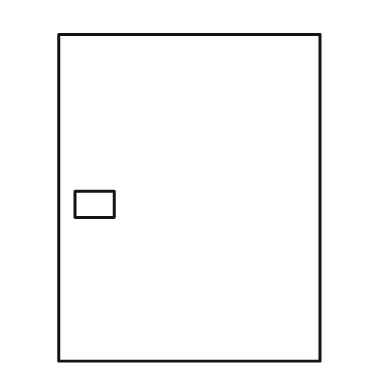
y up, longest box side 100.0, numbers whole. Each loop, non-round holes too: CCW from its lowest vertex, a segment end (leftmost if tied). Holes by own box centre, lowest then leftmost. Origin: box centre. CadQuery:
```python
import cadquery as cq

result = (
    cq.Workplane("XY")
    .moveTo(-40.0, -50.0)
    .lineTo(40.0, -50.0)
    .lineTo(40.0, 50.0)
    .lineTo(-40.0, 50.0)
    .close()
    .moveTo(-35.0, -6.0)
    .lineTo(-23.0, -6.0)
    .lineTo(-23.0, 2.0)
    .lineTo(-35.0, 2.0)
    .close()
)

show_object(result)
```